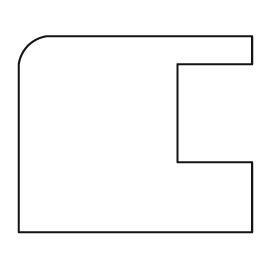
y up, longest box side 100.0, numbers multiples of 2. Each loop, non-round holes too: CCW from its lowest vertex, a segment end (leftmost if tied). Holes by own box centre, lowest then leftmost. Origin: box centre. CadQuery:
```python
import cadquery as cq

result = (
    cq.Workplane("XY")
    .moveTo(-50.0, -42.0)
    .lineTo(50.0, -42.0)
    .lineTo(50.0, -12.0)
    .lineTo(18.0, -12.0)
    .lineTo(18.0, 30.0)
    .lineTo(50.0, 30.0)
    .lineTo(50.0, 42.0)
    .lineTo(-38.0, 42.0)
    .threePointArc((-46.0, 38.0), (-50.0, 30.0))
    .close()
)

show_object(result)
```